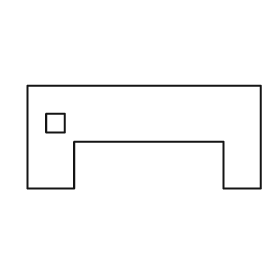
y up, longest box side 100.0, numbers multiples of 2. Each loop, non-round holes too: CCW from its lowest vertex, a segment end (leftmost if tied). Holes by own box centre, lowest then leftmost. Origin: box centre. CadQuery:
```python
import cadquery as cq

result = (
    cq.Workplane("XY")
    .moveTo(-50.0, -22.0)
    .lineTo(-30.0, -22.0)
    .lineTo(-30.0, -2.0)
    .lineTo(34.0, -2.0)
    .lineTo(34.0, -22.0)
    .lineTo(50.0, -22.0)
    .lineTo(50.0, 22.0)
    .lineTo(-50.0, 22.0)
    .close()
    .moveTo(-42.0, 2.0)
    .lineTo(-34.0, 2.0)
    .lineTo(-34.0, 10.0)
    .lineTo(-42.0, 10.0)
    .close()
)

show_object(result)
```